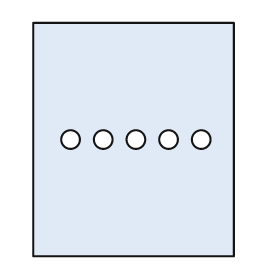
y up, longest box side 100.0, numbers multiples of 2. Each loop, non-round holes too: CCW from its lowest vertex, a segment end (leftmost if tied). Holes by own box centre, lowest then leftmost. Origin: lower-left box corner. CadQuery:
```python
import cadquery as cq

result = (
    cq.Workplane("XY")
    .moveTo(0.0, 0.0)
    .lineTo(86.0, 0.0)
    .lineTo(86.0, 100.0)
    .lineTo(0.0, 100.0)
    .close()
    .moveTo(16.0, 50.0)
    .circle(4.0)
    .moveTo(30.0, 50.0)
    .circle(4.0)
    .moveTo(44.0, 50.0)
    .circle(4.0)
    .moveTo(58.0, 50.0)
    .circle(4.0)
    .moveTo(72.0, 50.0)
    .circle(4.0)
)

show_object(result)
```